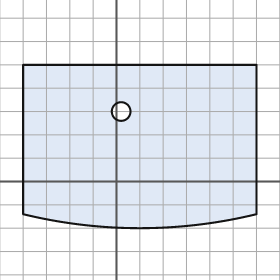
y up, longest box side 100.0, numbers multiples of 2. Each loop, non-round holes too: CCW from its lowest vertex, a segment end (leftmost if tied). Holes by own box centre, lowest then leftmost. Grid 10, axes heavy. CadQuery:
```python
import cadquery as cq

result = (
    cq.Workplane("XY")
    .moveTo(-40.0, -14.0)
    .threePointArc((10.0, -20.0), (60.0, -14.0))
    .lineTo(60.0, 50.0)
    .lineTo(-40.0, 50.0)
    .close()
    .moveTo(2.0, 30.0)
    .circle(4.0)
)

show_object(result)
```